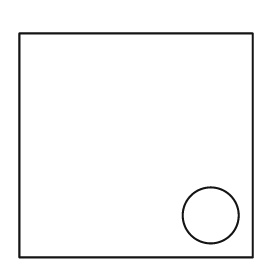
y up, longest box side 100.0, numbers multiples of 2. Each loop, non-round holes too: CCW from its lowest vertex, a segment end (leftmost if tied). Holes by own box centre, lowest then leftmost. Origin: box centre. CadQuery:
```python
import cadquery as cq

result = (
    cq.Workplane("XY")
    .moveTo(-50.0, -48.0)
    .lineTo(50.0, -48.0)
    .lineTo(50.0, 48.0)
    .lineTo(-50.0, 48.0)
    .close()
    .moveTo(32.0, -30.0)
    .circle(12.0)
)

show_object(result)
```